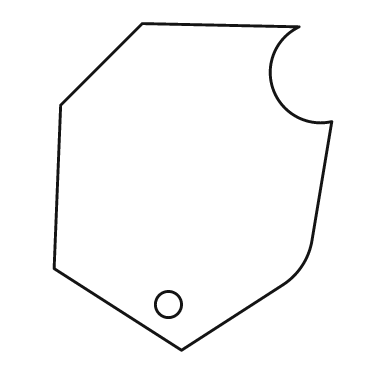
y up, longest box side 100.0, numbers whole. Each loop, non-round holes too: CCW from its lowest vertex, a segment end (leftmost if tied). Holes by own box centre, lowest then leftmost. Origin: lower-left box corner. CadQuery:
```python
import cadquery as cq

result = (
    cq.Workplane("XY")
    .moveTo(39.0, 0.0)
    .lineTo(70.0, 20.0)
    .threePointArc((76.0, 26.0), (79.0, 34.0))
    .lineTo(85.0, 70.0)
    .threePointArc((67.0, 80.0), (75.0, 99.0))
    .lineTo(27.0, 100.0)
    .lineTo(2.0, 75.0)
    .lineTo(0.0, 25.0)
    .close()
    .moveTo(35.0, 14.0)
    .circle(4.0)
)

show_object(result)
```